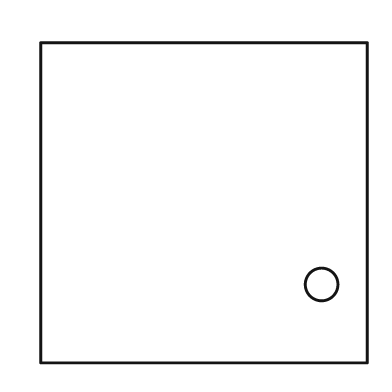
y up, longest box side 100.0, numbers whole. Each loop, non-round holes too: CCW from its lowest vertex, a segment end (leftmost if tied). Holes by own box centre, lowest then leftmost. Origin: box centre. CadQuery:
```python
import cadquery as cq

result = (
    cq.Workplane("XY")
    .moveTo(-50.0, -49.0)
    .lineTo(50.0, -49.0)
    .lineTo(50.0, 49.0)
    .lineTo(-50.0, 49.0)
    .close()
    .moveTo(36.0, -25.0)
    .circle(5.0)
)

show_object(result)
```